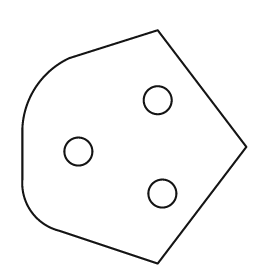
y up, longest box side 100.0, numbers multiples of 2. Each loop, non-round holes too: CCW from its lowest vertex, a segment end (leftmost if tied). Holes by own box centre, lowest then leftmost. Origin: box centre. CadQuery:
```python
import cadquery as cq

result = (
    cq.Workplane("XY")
    .moveTo(10.0, -50.0)
    .lineTo(48.0, 0.0)
    .lineTo(10.0, 50.0)
    .lineTo(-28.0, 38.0)
    .threePointArc((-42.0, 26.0), (-48.0, 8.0))
    .lineTo(-48.0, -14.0)
    .threePointArc((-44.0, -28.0), (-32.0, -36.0))
    .close()
    .moveTo(12.0, -20.0)
    .circle(6.0)
    .moveTo(-24.0, -2.0)
    .circle(6.0)
    .moveTo(10.0, 20.0)
    .circle(6.0)
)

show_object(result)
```